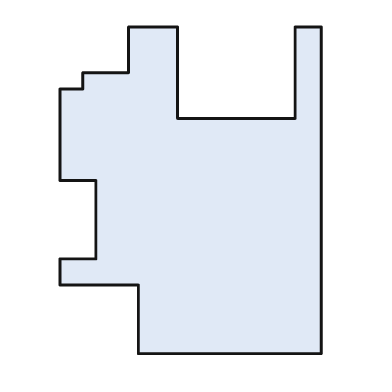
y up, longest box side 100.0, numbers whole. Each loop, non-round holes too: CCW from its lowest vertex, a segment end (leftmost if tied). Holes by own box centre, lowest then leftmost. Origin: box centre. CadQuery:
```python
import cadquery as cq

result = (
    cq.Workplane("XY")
    .moveTo(-16.0, -50.0)
    .lineTo(40.0, -50.0)
    .lineTo(40.0, 50.0)
    .lineTo(32.0, 50.0)
    .lineTo(32.0, 22.0)
    .lineTo(-4.0, 22.0)
    .lineTo(-4.0, 50.0)
    .lineTo(-19.0, 50.0)
    .lineTo(-19.0, 36.0)
    .lineTo(-33.0, 36.0)
    .lineTo(-33.0, 31.0)
    .lineTo(-40.0, 31.0)
    .lineTo(-40.0, 3.0)
    .lineTo(-29.0, 3.0)
    .lineTo(-29.0, -21.0)
    .lineTo(-40.0, -21.0)
    .lineTo(-40.0, -29.0)
    .lineTo(-16.0, -29.0)
    .close()
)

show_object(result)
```